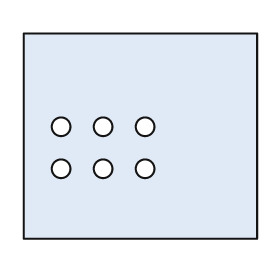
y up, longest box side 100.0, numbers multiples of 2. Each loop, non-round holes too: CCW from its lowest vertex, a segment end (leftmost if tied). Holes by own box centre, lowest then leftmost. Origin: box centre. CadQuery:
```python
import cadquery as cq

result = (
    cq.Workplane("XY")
    .moveTo(-50.0, -44.0)
    .lineTo(50.0, -44.0)
    .lineTo(50.0, 44.0)
    .lineTo(-50.0, 44.0)
    .close()
    .moveTo(-34.0, -14.0)
    .circle(4.0)
    .moveTo(-16.0, -14.0)
    .circle(4.0)
    .moveTo(2.0, -14.0)
    .circle(4.0)
    .moveTo(-34.0, 4.0)
    .circle(4.0)
    .moveTo(-16.0, 4.0)
    .circle(4.0)
    .moveTo(2.0, 4.0)
    .circle(4.0)
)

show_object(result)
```